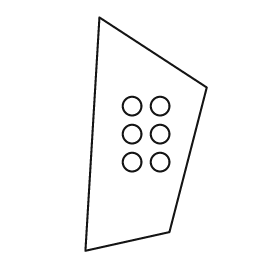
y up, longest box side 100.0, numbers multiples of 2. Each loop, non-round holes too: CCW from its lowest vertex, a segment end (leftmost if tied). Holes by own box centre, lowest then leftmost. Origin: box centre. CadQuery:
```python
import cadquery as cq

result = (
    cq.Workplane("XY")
    .moveTo(-26.0, -50.0)
    .lineTo(10.0, -42.0)
    .lineTo(26.0, 20.0)
    .lineTo(-20.0, 50.0)
    .close()
    .moveTo(-6.0, -12.0)
    .circle(4.0)
    .moveTo(6.0, -12.0)
    .circle(4.0)
    .moveTo(-6.0, 0.0)
    .circle(4.0)
    .moveTo(6.0, 0.0)
    .circle(4.0)
    .moveTo(-6.0, 12.0)
    .circle(4.0)
    .moveTo(6.0, 12.0)
    .circle(4.0)
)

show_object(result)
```